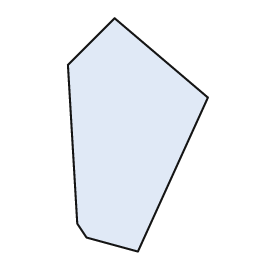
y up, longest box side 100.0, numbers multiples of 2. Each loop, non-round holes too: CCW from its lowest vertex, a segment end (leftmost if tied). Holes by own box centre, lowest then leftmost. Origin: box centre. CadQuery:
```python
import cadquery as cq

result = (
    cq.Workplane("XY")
    .moveTo(0.0, -50.0)
    .lineTo(30.0, 16.0)
    .lineTo(-10.0, 50.0)
    .lineTo(-30.0, 30.0)
    .lineTo(-26.0, -38.0)
    .lineTo(-22.0, -44.0)
    .close()
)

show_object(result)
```